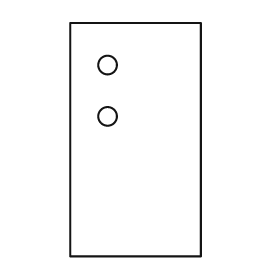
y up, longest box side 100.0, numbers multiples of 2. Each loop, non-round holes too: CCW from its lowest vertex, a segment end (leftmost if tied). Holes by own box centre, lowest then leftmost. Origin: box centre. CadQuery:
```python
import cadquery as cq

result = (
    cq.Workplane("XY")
    .moveTo(-28.0, -50.0)
    .lineTo(28.0, -50.0)
    .lineTo(28.0, 50.0)
    .lineTo(-28.0, 50.0)
    .close()
    .moveTo(-12.0, 10.0)
    .circle(4.0)
    .moveTo(-12.0, 32.0)
    .circle(4.0)
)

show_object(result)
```